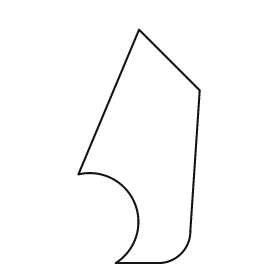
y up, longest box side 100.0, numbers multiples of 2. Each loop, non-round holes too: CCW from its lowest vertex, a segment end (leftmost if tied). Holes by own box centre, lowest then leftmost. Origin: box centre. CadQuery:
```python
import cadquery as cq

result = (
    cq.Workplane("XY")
    .moveTo(-10.0, -50.0)
    .lineTo(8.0, -50.0)
    .threePointArc((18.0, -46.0), (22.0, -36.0))
    .lineTo(26.0, 24.0)
    .lineTo(0.0, 50.0)
    .lineTo(-26.0, -12.0)
    .threePointArc((-2.0, -24.0), (-10.0, -50.0))
    .close()
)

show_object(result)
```